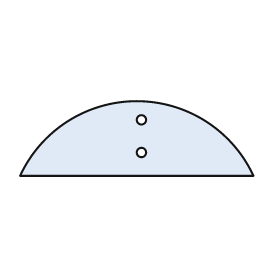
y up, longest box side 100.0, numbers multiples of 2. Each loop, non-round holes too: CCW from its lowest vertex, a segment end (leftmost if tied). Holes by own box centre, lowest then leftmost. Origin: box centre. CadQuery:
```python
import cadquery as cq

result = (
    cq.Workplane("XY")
    .moveTo(-50.0, -16.0)
    .lineTo(50.0, -16.0)
    .threePointArc((0.0, 16.0), (-50.0, -16.0))
    .close()
    .moveTo(2.0, -6.0)
    .circle(2.0)
    .moveTo(2.0, 8.0)
    .circle(2.0)
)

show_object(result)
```